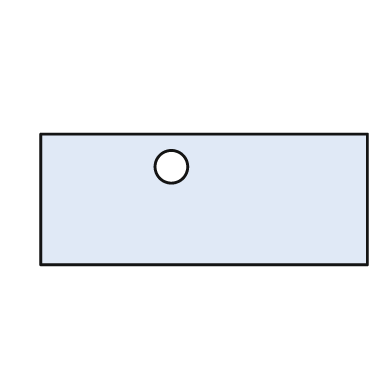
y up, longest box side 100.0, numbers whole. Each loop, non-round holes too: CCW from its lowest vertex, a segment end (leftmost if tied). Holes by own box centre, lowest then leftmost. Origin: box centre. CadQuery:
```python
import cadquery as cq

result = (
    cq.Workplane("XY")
    .moveTo(-50.0, -20.0)
    .lineTo(50.0, -20.0)
    .lineTo(50.0, 20.0)
    .lineTo(-50.0, 20.0)
    .close()
    .moveTo(-10.0, 10.0)
    .circle(5.0)
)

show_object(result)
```